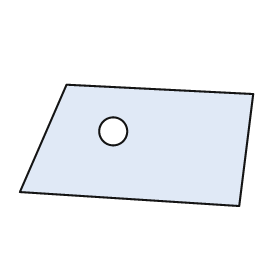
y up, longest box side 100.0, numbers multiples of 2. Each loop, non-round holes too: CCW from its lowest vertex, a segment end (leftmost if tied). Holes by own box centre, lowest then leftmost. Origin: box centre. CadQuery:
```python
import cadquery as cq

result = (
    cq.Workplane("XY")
    .moveTo(44.0, -26.0)
    .lineTo(50.0, 22.0)
    .lineTo(-30.0, 26.0)
    .lineTo(-50.0, -20.0)
    .close()
    .moveTo(-10.0, 6.0)
    .circle(6.0)
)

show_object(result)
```